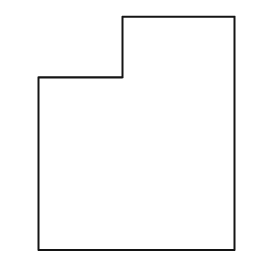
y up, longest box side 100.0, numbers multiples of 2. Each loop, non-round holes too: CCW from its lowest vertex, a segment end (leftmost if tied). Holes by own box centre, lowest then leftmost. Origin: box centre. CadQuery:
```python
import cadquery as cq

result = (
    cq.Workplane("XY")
    .moveTo(-42.0, -50.0)
    .lineTo(42.0, -50.0)
    .lineTo(42.0, 50.0)
    .lineTo(-6.0, 50.0)
    .lineTo(-6.0, 24.0)
    .lineTo(-42.0, 24.0)
    .close()
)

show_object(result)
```